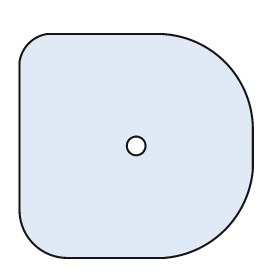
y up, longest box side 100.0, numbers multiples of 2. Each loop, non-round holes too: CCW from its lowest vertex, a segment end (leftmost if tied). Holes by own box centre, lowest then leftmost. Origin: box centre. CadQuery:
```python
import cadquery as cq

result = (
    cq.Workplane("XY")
    .moveTo(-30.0, -48.0)
    .lineTo(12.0, -48.0)
    .threePointArc((38.0, -36.0), (50.0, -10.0))
    .lineTo(50.0, 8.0)
    .threePointArc((38.0, 36.0), (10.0, 48.0))
    .lineTo(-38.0, 48.0)
    .threePointArc((-46.0, 44.0), (-50.0, 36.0))
    .lineTo(-50.0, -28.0)
    .threePointArc((-44.0, -42.0), (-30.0, -48.0))
    .close()
    .moveTo(0.0, 0.0)
    .circle(4.0)
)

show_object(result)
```